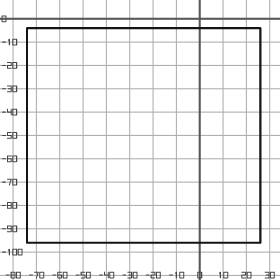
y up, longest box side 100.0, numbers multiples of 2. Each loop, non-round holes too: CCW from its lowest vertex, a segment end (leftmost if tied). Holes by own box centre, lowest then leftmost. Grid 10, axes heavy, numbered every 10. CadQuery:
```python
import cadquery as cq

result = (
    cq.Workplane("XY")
    .moveTo(-74.0, -96.0)
    .lineTo(26.0, -96.0)
    .lineTo(26.0, -4.0)
    .lineTo(-74.0, -4.0)
    .close()
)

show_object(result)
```